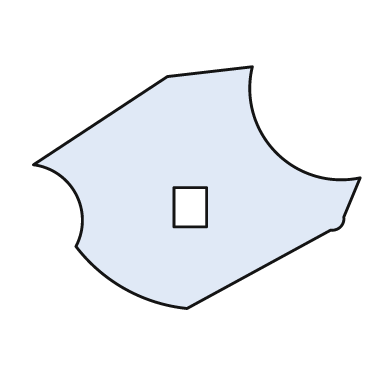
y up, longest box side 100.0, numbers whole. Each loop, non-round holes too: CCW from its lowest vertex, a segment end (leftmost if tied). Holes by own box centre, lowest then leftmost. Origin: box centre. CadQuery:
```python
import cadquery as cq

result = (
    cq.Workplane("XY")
    .moveTo(-3.0, -37.0)
    .lineTo(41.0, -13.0)
    .threePointArc((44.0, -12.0), (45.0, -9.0))
    .lineTo(50.0, 3.0)
    .threePointArc((24.0, 11.0), (17.0, 37.0))
    .lineTo(-9.0, 34.0)
    .lineTo(-50.0, 7.0)
    .threePointArc((-37.0, -2.0), (-37.0, -18.0))
    .threePointArc((-22.0, -31.0), (-3.0, -37.0))
    .close()
    .moveTo(-7.0, -12.0)
    .lineTo(3.0, -12.0)
    .lineTo(3.0, 0.0)
    .lineTo(-7.0, 0.0)
    .close()
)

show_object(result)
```